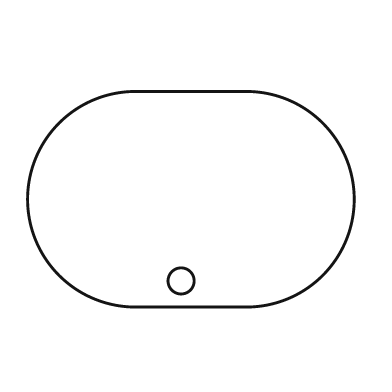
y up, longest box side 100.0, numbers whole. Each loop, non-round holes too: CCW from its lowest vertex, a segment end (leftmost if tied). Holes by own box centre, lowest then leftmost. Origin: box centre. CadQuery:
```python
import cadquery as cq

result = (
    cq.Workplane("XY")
    .moveTo(-17.0, -33.0)
    .lineTo(17.0, -33.0)
    .threePointArc((50.0, 0.0), (17.0, 33.0))
    .lineTo(-17.0, 33.0)
    .threePointArc((-50.0, 0.0), (-17.0, -33.0))
    .close()
    .moveTo(-3.0, -25.0)
    .circle(4.0)
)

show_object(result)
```